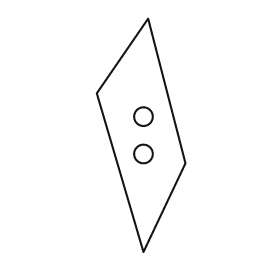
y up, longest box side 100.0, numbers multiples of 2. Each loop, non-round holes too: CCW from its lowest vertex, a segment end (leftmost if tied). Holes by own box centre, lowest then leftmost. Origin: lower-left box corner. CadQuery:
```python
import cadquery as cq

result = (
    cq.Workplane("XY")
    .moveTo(20.0, 0.0)
    .lineTo(38.0, 38.0)
    .lineTo(22.0, 100.0)
    .lineTo(0.0, 68.0)
    .close()
    .moveTo(20.0, 42.0)
    .circle(4.0)
    .moveTo(20.0, 58.0)
    .circle(4.0)
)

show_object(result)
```